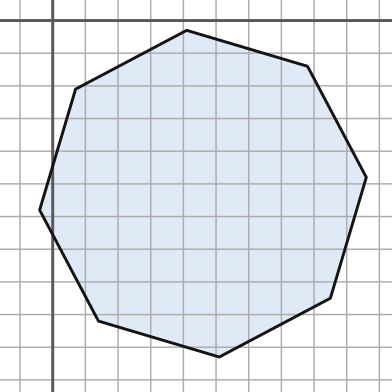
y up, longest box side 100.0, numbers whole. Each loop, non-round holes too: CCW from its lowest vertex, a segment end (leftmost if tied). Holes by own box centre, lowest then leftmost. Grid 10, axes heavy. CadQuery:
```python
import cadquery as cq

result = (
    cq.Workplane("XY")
    .moveTo(51.0, -103.0)
    .lineTo(85.0, -85.0)
    .lineTo(96.0, -48.0)
    .lineTo(78.0, -14.0)
    .lineTo(41.0, -3.0)
    .lineTo(7.0, -21.0)
    .lineTo(-4.0, -58.0)
    .lineTo(14.0, -92.0)
    .close()
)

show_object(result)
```